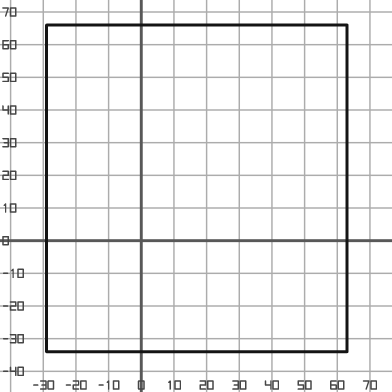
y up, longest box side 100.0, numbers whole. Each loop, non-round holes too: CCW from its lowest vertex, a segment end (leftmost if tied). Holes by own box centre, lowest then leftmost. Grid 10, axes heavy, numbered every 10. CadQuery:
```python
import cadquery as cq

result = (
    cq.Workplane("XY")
    .moveTo(-29.0, -34.0)
    .lineTo(63.0, -34.0)
    .lineTo(63.0, 66.0)
    .lineTo(-29.0, 66.0)
    .close()
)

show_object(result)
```